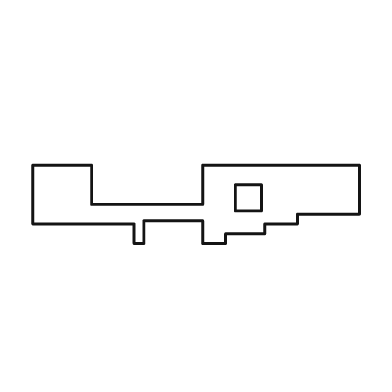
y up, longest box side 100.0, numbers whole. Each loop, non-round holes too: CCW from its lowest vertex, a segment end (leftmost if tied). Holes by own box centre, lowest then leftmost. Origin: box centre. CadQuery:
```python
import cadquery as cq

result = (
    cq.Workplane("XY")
    .moveTo(-19.0, -12.0)
    .lineTo(-16.0, -12.0)
    .lineTo(-16.0, -5.0)
    .lineTo(2.0, -5.0)
    .lineTo(2.0, -12.0)
    .lineTo(9.0, -12.0)
    .lineTo(9.0, -9.0)
    .lineTo(21.0, -9.0)
    .lineTo(21.0, -6.0)
    .lineTo(31.0, -6.0)
    .lineTo(31.0, -3.0)
    .lineTo(50.0, -3.0)
    .lineTo(50.0, 12.0)
    .lineTo(2.0, 12.0)
    .lineTo(2.0, 0.0)
    .lineTo(-32.0, 0.0)
    .lineTo(-32.0, 12.0)
    .lineTo(-50.0, 12.0)
    .lineTo(-50.0, -6.0)
    .lineTo(-19.0, -6.0)
    .close()
    .moveTo(12.0, -2.0)
    .lineTo(20.0, -2.0)
    .lineTo(20.0, 6.0)
    .lineTo(12.0, 6.0)
    .close()
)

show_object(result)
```